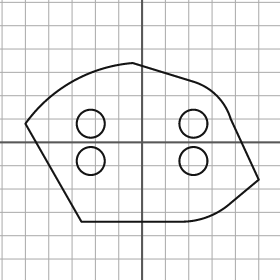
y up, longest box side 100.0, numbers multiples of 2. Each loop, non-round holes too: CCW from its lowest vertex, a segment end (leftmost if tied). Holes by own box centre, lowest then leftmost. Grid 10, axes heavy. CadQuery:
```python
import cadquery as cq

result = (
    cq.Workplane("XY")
    .moveTo(-26.0, -34.0)
    .lineTo(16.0, -34.0)
    .threePointArc((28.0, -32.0), (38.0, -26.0))
    .lineTo(50.0, -16.0)
    .lineTo(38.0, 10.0)
    .threePointArc((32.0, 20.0), (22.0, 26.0))
    .lineTo(-4.0, 34.0)
    .threePointArc((-30.0, 26.0), (-50.0, 8.0))
    .close()
    .moveTo(-22.0, -8.0)
    .circle(6.0)
    .moveTo(22.0, -8.0)
    .circle(6.0)
    .moveTo(-22.0, 8.0)
    .circle(6.0)
    .moveTo(22.0, 8.0)
    .circle(6.0)
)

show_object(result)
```